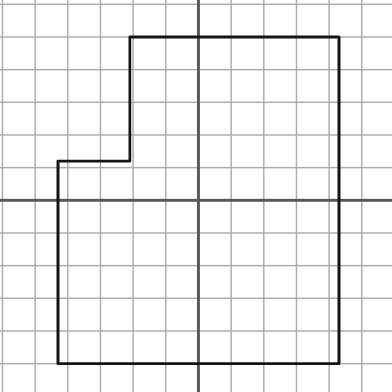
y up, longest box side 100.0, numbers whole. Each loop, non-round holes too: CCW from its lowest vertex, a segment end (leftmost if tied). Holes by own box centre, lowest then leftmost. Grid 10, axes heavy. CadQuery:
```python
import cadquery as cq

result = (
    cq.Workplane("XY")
    .moveTo(-43.0, -50.0)
    .lineTo(43.0, -50.0)
    .lineTo(43.0, 50.0)
    .lineTo(-21.0, 50.0)
    .lineTo(-21.0, 12.0)
    .lineTo(-43.0, 12.0)
    .close()
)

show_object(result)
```